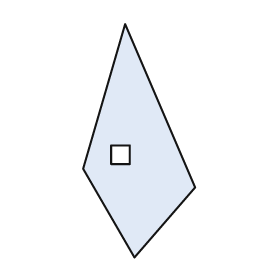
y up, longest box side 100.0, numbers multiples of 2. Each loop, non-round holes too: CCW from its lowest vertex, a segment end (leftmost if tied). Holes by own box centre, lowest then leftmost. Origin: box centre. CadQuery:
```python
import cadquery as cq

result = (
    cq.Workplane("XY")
    .moveTo(-2.0, -50.0)
    .lineTo(24.0, -20.0)
    .lineTo(-6.0, 50.0)
    .lineTo(-24.0, -12.0)
    .close()
    .moveTo(-12.0, -10.0)
    .lineTo(-4.0, -10.0)
    .lineTo(-4.0, -2.0)
    .lineTo(-12.0, -2.0)
    .close()
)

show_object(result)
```